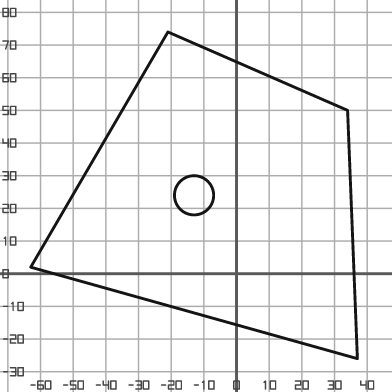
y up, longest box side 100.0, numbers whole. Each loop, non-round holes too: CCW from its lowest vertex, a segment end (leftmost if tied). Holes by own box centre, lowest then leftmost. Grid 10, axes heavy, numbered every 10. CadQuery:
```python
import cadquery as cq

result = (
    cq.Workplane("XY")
    .moveTo(37.0, -26.0)
    .lineTo(34.0, 50.0)
    .lineTo(-21.0, 74.0)
    .lineTo(-63.0, 2.0)
    .close()
    .moveTo(-13.0, 24.0)
    .circle(6.0)
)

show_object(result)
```